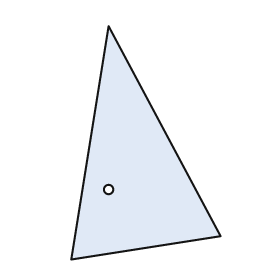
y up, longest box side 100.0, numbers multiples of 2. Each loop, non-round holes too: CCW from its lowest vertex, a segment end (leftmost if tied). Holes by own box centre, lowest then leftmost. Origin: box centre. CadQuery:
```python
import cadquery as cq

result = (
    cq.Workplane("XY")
    .moveTo(-32.0, -50.0)
    .lineTo(32.0, -40.0)
    .lineTo(-16.0, 50.0)
    .close()
    .moveTo(-16.0, -20.0)
    .circle(2.0)
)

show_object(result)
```